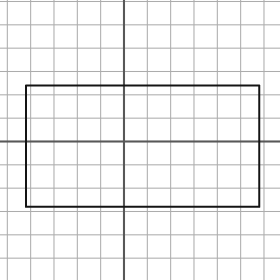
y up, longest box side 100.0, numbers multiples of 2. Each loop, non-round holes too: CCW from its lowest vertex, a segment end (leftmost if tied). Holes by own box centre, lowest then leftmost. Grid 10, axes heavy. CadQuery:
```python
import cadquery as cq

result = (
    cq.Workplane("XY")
    .moveTo(-42.0, -28.0)
    .lineTo(58.0, -28.0)
    .lineTo(58.0, 24.0)
    .lineTo(-42.0, 24.0)
    .close()
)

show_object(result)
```